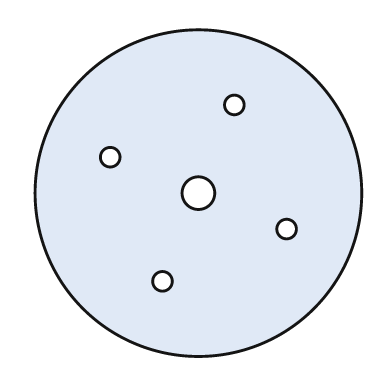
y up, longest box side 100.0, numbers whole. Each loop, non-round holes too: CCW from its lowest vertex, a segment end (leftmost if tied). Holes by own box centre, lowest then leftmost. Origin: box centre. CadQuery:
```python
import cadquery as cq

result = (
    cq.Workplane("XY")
    .moveTo(0.0, 0.0)
    .circle(50.0)
    .moveTo(-11.0, -27.0)
    .circle(3.0)
    .moveTo(27.0, -11.0)
    .circle(3.0)
    .moveTo(0.0, 0.0)
    .circle(5.0)
    .moveTo(-27.0, 11.0)
    .circle(3.0)
    .moveTo(11.0, 27.0)
    .circle(3.0)
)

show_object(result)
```